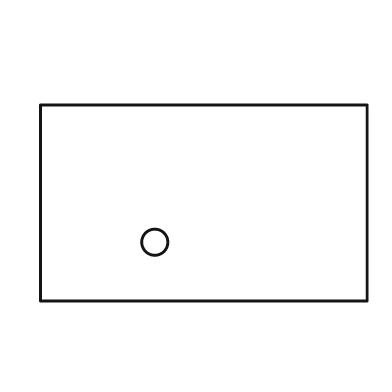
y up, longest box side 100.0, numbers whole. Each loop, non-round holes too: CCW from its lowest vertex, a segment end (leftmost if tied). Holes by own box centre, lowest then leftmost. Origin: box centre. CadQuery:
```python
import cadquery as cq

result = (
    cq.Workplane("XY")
    .moveTo(-50.0, -30.0)
    .lineTo(50.0, -30.0)
    .lineTo(50.0, 30.0)
    .lineTo(-50.0, 30.0)
    .close()
    .moveTo(-15.0, -12.0)
    .circle(4.0)
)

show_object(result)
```